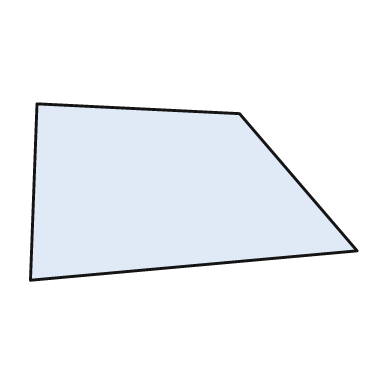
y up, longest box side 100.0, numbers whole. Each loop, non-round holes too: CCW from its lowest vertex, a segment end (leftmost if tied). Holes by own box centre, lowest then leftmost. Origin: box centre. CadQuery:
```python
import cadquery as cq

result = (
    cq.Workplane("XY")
    .moveTo(-50.0, -27.0)
    .lineTo(50.0, -18.0)
    .lineTo(14.0, 24.0)
    .lineTo(-48.0, 27.0)
    .close()
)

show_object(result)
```